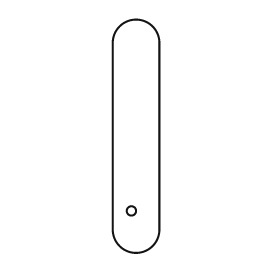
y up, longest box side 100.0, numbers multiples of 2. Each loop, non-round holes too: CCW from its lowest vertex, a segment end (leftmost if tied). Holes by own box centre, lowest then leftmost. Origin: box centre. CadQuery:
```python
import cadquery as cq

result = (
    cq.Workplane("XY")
    .moveTo(-10.0, -40.0)
    .threePointArc((0.0, -50.0), (10.0, -40.0))
    .lineTo(10.0, 40.0)
    .threePointArc((0.0, 50.0), (-10.0, 40.0))
    .close()
    .moveTo(-2.0, -32.0)
    .circle(2.0)
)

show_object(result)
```